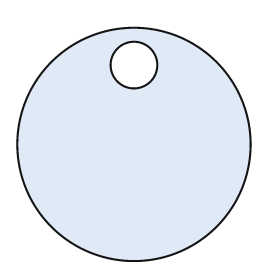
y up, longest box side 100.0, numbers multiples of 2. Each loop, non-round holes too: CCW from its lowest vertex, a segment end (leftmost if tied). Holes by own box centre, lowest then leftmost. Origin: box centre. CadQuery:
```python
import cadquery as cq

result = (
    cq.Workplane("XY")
    .moveTo(0.0, 0.0)
    .circle(50.0)
    .moveTo(0.0, 34.0)
    .circle(10.0)
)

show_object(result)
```